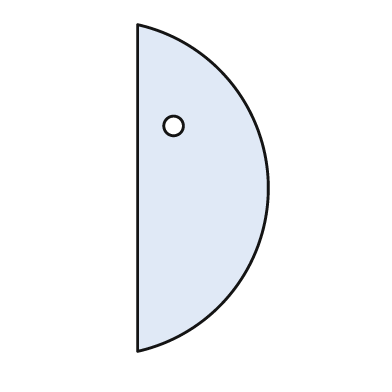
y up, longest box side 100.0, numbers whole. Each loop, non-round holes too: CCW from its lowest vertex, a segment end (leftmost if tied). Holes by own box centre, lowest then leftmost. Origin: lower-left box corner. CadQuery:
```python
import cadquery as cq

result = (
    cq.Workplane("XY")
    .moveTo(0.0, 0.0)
    .threePointArc((40.0, 50.0), (0.0, 100.0))
    .close()
    .moveTo(11.0, 69.0)
    .circle(3.0)
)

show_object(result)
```